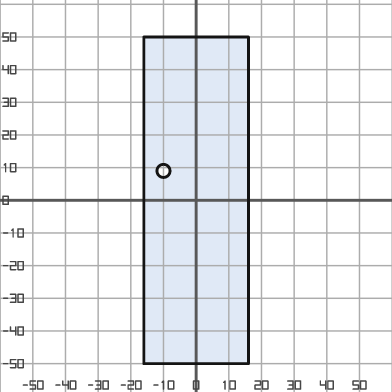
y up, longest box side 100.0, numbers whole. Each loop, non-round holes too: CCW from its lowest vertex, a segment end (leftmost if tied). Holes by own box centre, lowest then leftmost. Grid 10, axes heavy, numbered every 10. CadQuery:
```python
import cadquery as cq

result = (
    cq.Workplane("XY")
    .moveTo(-16.0, -50.0)
    .lineTo(16.0, -50.0)
    .lineTo(16.0, 50.0)
    .lineTo(-16.0, 50.0)
    .close()
    .moveTo(-10.0, 9.0)
    .circle(2.0)
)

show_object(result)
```